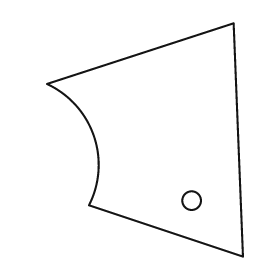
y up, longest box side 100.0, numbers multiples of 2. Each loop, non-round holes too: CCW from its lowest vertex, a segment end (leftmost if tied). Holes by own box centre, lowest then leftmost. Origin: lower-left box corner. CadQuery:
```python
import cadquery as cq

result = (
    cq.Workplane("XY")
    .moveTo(84.0, 0.0)
    .lineTo(80.0, 100.0)
    .lineTo(0.0, 74.0)
    .threePointArc((20.0, 52.0), (18.0, 22.0))
    .close()
    .moveTo(62.0, 24.0)
    .circle(4.0)
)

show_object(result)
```